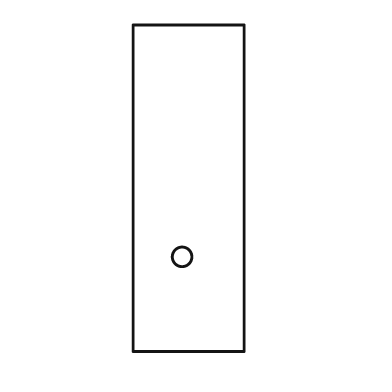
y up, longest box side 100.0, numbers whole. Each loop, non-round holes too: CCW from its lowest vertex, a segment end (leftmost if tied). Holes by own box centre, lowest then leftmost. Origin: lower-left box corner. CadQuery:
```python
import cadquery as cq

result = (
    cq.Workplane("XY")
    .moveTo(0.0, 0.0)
    .lineTo(34.0, 0.0)
    .lineTo(34.0, 100.0)
    .lineTo(0.0, 100.0)
    .close()
    .moveTo(15.0, 29.0)
    .circle(3.0)
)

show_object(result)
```